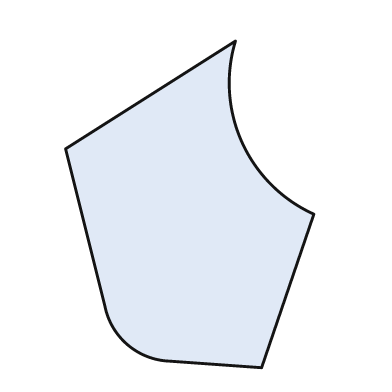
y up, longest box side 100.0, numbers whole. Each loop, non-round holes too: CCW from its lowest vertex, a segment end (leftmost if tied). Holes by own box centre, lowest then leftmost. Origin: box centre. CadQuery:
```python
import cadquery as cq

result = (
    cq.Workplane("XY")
    .moveTo(22.0, -50.0)
    .lineTo(38.0, -3.0)
    .threePointArc((16.0, 19.0), (14.0, 50.0))
    .lineTo(-38.0, 17.0)
    .lineTo(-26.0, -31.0)
    .threePointArc((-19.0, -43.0), (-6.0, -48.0))
    .close()
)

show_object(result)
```